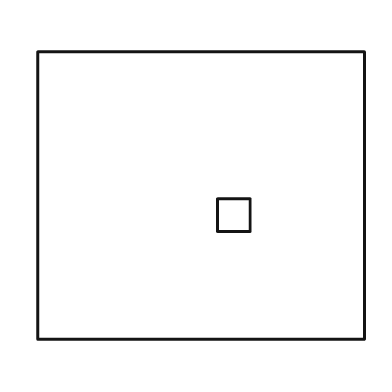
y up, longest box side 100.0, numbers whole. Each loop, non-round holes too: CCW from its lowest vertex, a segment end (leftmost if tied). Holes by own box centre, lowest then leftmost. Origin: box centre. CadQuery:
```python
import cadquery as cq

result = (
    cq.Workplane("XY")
    .moveTo(-50.0, -44.0)
    .lineTo(50.0, -44.0)
    .lineTo(50.0, 44.0)
    .lineTo(-50.0, 44.0)
    .close()
    .moveTo(5.0, -11.0)
    .lineTo(15.0, -11.0)
    .lineTo(15.0, -1.0)
    .lineTo(5.0, -1.0)
    .close()
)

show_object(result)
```